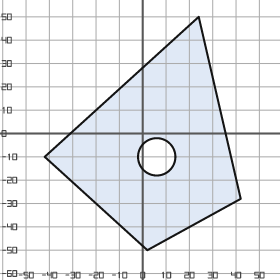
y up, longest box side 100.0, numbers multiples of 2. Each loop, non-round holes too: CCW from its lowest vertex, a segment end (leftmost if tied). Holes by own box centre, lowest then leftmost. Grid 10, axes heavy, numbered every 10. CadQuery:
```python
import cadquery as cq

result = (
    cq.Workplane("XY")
    .moveTo(2.0, -50.0)
    .lineTo(42.0, -28.0)
    .lineTo(24.0, 50.0)
    .lineTo(-42.0, -10.0)
    .close()
    .moveTo(6.0, -10.0)
    .circle(8.0)
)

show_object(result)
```